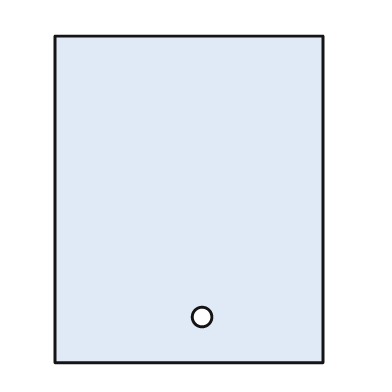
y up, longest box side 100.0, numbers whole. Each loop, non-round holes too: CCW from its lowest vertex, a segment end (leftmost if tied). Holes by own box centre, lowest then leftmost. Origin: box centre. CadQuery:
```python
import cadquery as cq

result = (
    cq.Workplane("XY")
    .moveTo(-41.0, -50.0)
    .lineTo(41.0, -50.0)
    .lineTo(41.0, 50.0)
    .lineTo(-41.0, 50.0)
    .close()
    .moveTo(4.0, -36.0)
    .circle(3.0)
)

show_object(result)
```